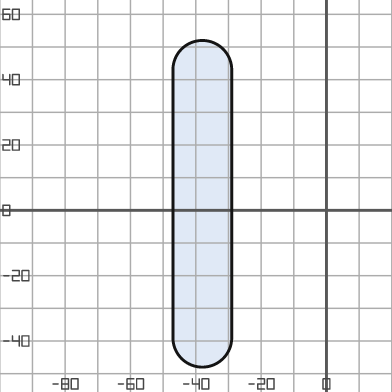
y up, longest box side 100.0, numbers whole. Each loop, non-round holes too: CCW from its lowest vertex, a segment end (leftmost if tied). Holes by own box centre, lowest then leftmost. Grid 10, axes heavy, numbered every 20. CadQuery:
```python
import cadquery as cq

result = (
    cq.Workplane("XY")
    .moveTo(-47.0, -39.0)
    .threePointArc((-38.0, -48.0), (-29.0, -39.0))
    .lineTo(-29.0, 43.0)
    .threePointArc((-38.0, 52.0), (-47.0, 43.0))
    .close()
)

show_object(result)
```